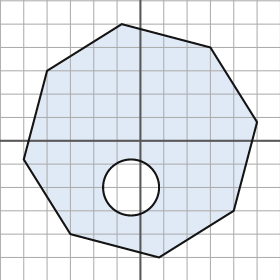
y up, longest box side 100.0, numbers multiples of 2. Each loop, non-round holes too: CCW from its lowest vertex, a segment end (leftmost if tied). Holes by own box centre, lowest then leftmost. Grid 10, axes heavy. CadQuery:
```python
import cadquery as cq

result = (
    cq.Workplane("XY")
    .moveTo(8.0, -50.0)
    .lineTo(40.0, -30.0)
    .lineTo(50.0, 8.0)
    .lineTo(30.0, 40.0)
    .lineTo(-8.0, 50.0)
    .lineTo(-40.0, 30.0)
    .lineTo(-50.0, -8.0)
    .lineTo(-30.0, -40.0)
    .close()
    .moveTo(-4.0, -20.0)
    .circle(12.0)
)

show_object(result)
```